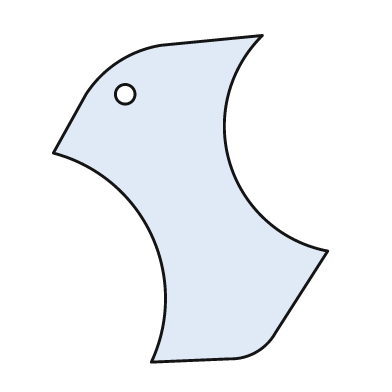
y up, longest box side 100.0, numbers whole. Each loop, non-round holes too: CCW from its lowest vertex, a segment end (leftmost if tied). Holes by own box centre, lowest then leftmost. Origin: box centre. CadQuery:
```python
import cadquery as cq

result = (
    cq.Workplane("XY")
    .moveTo(-12.0, -50.0)
    .lineTo(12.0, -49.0)
    .threePointArc((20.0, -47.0), (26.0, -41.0))
    .lineTo(42.0, -16.0)
    .threePointArc((12.0, 11.0), (22.0, 50.0))
    .lineTo(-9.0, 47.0)
    .threePointArc((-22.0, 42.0), (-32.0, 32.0))
    .lineTo(-42.0, 14.0)
    .threePointArc((-12.0, -11.0), (-12.0, -50.0))
    .close()
    .moveTo(-20.0, 32.0)
    .circle(3.0)
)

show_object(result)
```